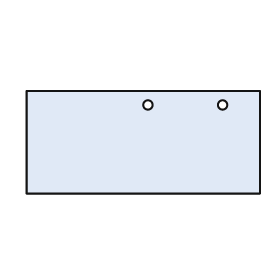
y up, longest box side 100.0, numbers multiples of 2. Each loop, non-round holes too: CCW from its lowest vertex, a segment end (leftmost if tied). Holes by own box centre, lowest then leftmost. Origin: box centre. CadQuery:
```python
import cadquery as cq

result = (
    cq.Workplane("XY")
    .moveTo(-50.0, -22.0)
    .lineTo(50.0, -22.0)
    .lineTo(50.0, 22.0)
    .lineTo(-50.0, 22.0)
    .close()
    .moveTo(2.0, 16.0)
    .circle(2.0)
    .moveTo(34.0, 16.0)
    .circle(2.0)
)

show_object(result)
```